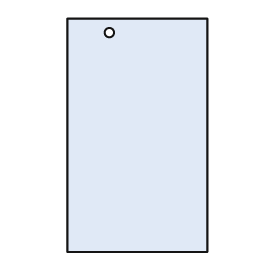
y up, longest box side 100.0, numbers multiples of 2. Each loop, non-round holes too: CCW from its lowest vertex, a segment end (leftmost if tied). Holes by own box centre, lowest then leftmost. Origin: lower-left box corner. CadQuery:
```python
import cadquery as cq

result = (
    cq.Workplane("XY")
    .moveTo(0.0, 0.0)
    .lineTo(60.0, 0.0)
    .lineTo(60.0, 100.0)
    .lineTo(0.0, 100.0)
    .close()
    .moveTo(18.0, 94.0)
    .circle(2.0)
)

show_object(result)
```